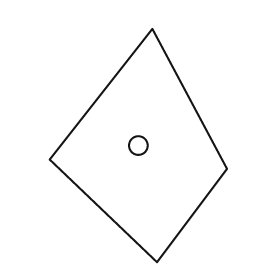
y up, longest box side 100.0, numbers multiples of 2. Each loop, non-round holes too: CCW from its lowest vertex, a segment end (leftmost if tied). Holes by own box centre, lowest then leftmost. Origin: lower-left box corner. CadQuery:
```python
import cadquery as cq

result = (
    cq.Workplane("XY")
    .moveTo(46.0, 0.0)
    .lineTo(76.0, 40.0)
    .lineTo(44.0, 100.0)
    .lineTo(0.0, 44.0)
    .close()
    .moveTo(38.0, 50.0)
    .circle(4.0)
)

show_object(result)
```